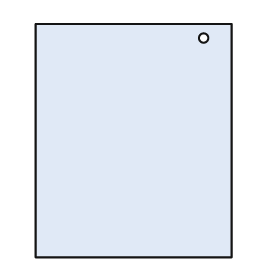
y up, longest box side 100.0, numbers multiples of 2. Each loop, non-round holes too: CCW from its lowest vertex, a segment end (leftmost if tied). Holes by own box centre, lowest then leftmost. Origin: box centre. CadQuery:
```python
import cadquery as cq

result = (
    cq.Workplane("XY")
    .moveTo(-42.0, -50.0)
    .lineTo(42.0, -50.0)
    .lineTo(42.0, 50.0)
    .lineTo(-42.0, 50.0)
    .close()
    .moveTo(30.0, 44.0)
    .circle(2.0)
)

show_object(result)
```